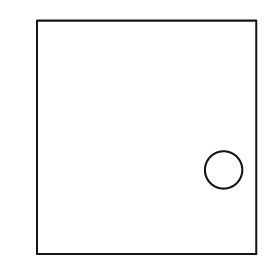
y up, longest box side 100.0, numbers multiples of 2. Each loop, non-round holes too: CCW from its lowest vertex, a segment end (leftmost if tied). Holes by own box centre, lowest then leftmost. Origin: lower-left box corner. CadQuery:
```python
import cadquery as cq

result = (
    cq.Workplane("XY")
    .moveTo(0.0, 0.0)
    .lineTo(94.0, 0.0)
    .lineTo(94.0, 100.0)
    .lineTo(0.0, 100.0)
    .close()
    .moveTo(80.0, 36.0)
    .circle(8.0)
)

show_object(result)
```